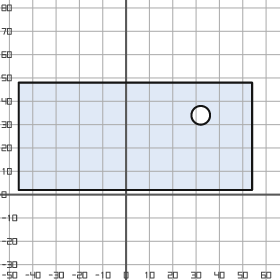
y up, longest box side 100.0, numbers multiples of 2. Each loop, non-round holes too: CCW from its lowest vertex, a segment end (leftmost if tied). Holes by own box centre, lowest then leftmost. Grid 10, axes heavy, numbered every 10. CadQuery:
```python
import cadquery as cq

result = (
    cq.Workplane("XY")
    .moveTo(-46.0, 2.0)
    .lineTo(54.0, 2.0)
    .lineTo(54.0, 48.0)
    .lineTo(-46.0, 48.0)
    .close()
    .moveTo(32.0, 34.0)
    .circle(4.0)
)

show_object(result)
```